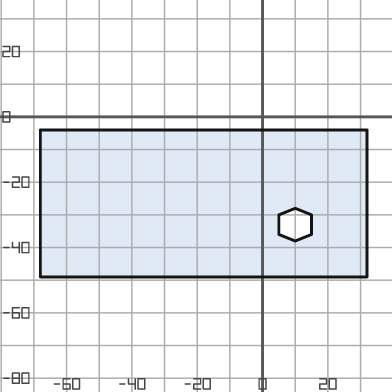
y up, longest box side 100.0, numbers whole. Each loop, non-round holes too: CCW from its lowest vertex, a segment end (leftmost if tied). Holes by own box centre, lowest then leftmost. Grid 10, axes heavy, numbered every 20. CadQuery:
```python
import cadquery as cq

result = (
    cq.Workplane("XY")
    .moveTo(-68.0, -49.0)
    .lineTo(32.0, -49.0)
    .lineTo(32.0, -4.0)
    .lineTo(-68.0, -4.0)
    .close()
    .moveTo(10.0, -38.0)
    .lineTo(15.0, -36.0)
    .lineTo(15.0, -30.0)
    .lineTo(10.0, -28.0)
    .lineTo(5.0, -30.0)
    .lineTo(5.0, -36.0)
    .close()
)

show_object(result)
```